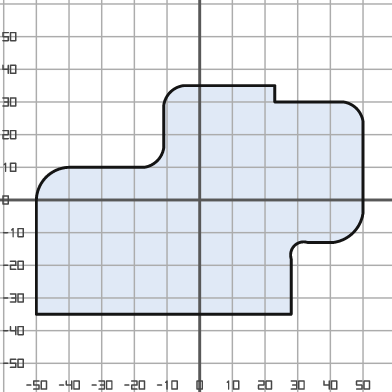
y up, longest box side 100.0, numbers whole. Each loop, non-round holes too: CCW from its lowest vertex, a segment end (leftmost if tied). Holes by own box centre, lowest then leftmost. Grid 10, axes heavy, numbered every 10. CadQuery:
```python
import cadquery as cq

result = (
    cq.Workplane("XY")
    .moveTo(-50.0, -35.0)
    .lineTo(28.0, -35.0)
    .lineTo(28.0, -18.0)
    .threePointArc((29.0, -14.0), (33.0, -13.0))
    .lineTo(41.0, -13.0)
    .threePointArc((47.0, -10.0), (50.0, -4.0))
    .lineTo(50.0, 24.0)
    .threePointArc((48.0, 28.0), (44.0, 30.0))
    .lineTo(23.0, 30.0)
    .lineTo(23.0, 35.0)
    .lineTo(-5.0, 35.0)
    .threePointArc((-9.0, 33.0), (-11.0, 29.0))
    .lineTo(-11.0, 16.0)
    .threePointArc((-13.0, 12.0), (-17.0, 10.0))
    .lineTo(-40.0, 10.0)
    .threePointArc((-47.0, 7.0), (-50.0, 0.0))
    .close()
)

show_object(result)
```